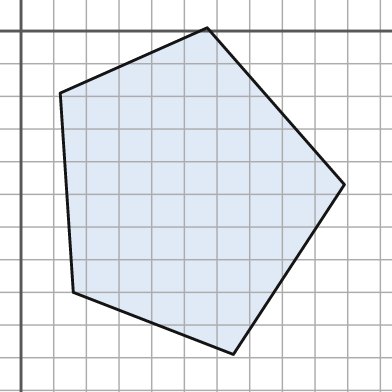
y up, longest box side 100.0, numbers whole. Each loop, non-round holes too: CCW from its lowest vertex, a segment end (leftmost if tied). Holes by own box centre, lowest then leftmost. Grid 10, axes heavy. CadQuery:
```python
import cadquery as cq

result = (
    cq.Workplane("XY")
    .moveTo(65.0, -99.0)
    .lineTo(99.0, -47.0)
    .lineTo(57.0, 1.0)
    .lineTo(12.0, -19.0)
    .lineTo(16.0, -80.0)
    .close()
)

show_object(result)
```